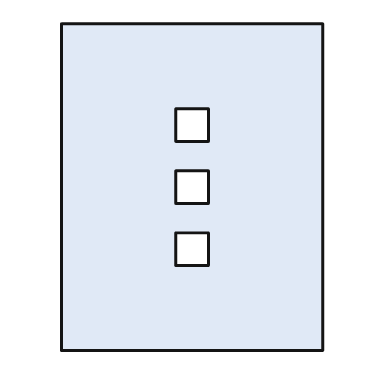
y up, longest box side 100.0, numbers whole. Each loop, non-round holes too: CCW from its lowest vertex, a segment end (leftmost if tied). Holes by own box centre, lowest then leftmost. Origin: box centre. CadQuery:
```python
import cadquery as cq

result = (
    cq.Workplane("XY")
    .moveTo(-40.0, -50.0)
    .lineTo(40.0, -50.0)
    .lineTo(40.0, 50.0)
    .lineTo(-40.0, 50.0)
    .close()
    .moveTo(-5.0, -24.0)
    .lineTo(5.0, -24.0)
    .lineTo(5.0, -14.0)
    .lineTo(-5.0, -14.0)
    .close()
    .moveTo(-5.0, -5.0)
    .lineTo(5.0, -5.0)
    .lineTo(5.0, 5.0)
    .lineTo(-5.0, 5.0)
    .close()
    .moveTo(-5.0, 14.0)
    .lineTo(5.0, 14.0)
    .lineTo(5.0, 24.0)
    .lineTo(-5.0, 24.0)
    .close()
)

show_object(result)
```